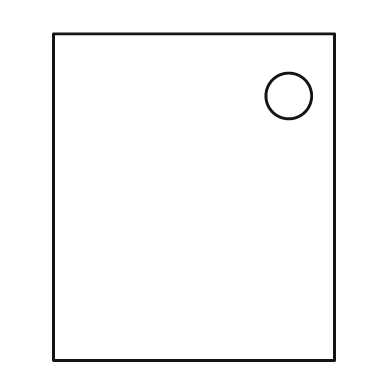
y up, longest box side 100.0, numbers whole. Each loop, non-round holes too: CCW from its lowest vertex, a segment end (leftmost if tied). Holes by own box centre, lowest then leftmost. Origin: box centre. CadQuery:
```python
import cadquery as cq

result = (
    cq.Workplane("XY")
    .moveTo(-43.0, -50.0)
    .lineTo(43.0, -50.0)
    .lineTo(43.0, 50.0)
    .lineTo(-43.0, 50.0)
    .close()
    .moveTo(29.0, 31.0)
    .circle(7.0)
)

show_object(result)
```